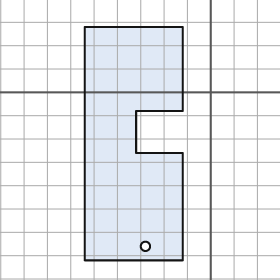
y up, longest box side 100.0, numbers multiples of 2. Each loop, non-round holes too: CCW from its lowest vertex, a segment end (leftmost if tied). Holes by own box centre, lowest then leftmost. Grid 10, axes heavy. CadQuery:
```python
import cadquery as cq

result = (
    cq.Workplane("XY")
    .moveTo(-54.0, -72.0)
    .lineTo(-12.0, -72.0)
    .lineTo(-12.0, -26.0)
    .lineTo(-32.0, -26.0)
    .lineTo(-32.0, -8.0)
    .lineTo(-12.0, -8.0)
    .lineTo(-12.0, 28.0)
    .lineTo(-54.0, 28.0)
    .close()
    .moveTo(-28.0, -66.0)
    .circle(2.0)
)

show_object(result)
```